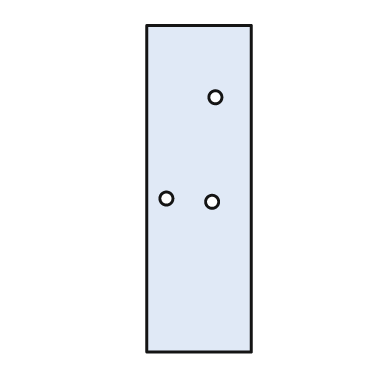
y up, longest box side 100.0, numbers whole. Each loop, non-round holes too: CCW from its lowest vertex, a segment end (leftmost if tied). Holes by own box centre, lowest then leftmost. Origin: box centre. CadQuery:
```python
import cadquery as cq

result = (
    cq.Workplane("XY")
    .moveTo(-16.0, -50.0)
    .lineTo(16.0, -50.0)
    .lineTo(16.0, 50.0)
    .lineTo(-16.0, 50.0)
    .close()
    .moveTo(4.0, -4.0)
    .circle(2.0)
    .moveTo(-10.0, -3.0)
    .circle(2.0)
    .moveTo(5.0, 28.0)
    .circle(2.0)
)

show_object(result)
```